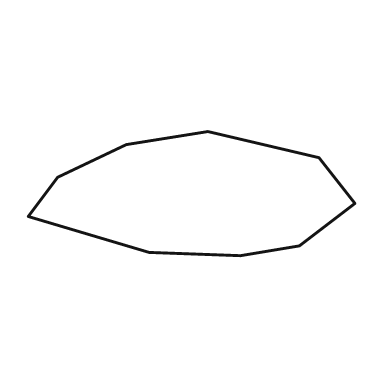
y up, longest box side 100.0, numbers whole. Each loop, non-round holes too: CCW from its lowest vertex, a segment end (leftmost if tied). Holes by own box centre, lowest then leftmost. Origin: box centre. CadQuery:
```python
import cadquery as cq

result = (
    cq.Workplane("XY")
    .moveTo(15.0, -19.0)
    .lineTo(33.0, -16.0)
    .lineTo(50.0, -3.0)
    .lineTo(39.0, 11.0)
    .lineTo(5.0, 19.0)
    .lineTo(-20.0, 15.0)
    .lineTo(-41.0, 5.0)
    .lineTo(-50.0, -7.0)
    .lineTo(-13.0, -18.0)
    .close()
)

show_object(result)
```